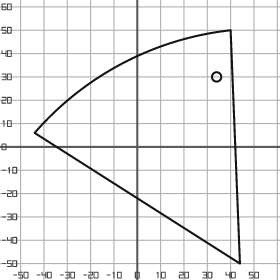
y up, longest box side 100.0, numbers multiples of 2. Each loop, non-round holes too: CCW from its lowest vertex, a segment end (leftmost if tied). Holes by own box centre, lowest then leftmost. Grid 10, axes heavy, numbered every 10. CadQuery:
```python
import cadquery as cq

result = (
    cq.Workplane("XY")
    .moveTo(44.0, -50.0)
    .lineTo(40.0, 50.0)
    .threePointArc((-6.0, 36.0), (-44.0, 6.0))
    .close()
    .moveTo(34.0, 30.0)
    .circle(2.0)
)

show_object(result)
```